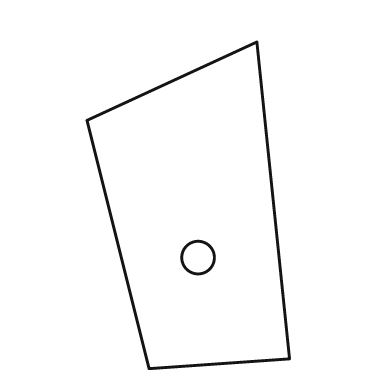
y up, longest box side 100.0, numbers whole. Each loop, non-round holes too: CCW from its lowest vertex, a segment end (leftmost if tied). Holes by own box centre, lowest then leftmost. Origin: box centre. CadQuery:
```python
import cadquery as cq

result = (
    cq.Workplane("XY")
    .moveTo(-12.0, -50.0)
    .lineTo(31.0, -47.0)
    .lineTo(21.0, 50.0)
    .lineTo(-31.0, 26.0)
    .close()
    .moveTo(3.0, -16.0)
    .circle(5.0)
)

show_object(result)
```